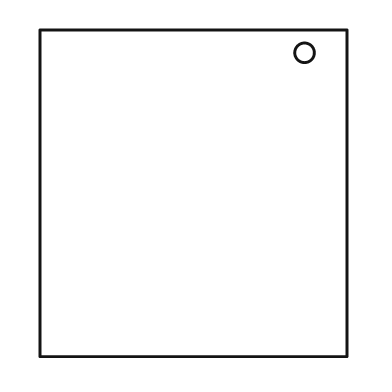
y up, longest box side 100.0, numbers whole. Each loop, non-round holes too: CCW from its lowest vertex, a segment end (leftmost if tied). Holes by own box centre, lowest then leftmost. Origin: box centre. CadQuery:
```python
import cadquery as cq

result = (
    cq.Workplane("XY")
    .moveTo(-47.0, -50.0)
    .lineTo(47.0, -50.0)
    .lineTo(47.0, 50.0)
    .lineTo(-47.0, 50.0)
    .close()
    .moveTo(34.0, 43.0)
    .circle(3.0)
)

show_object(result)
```